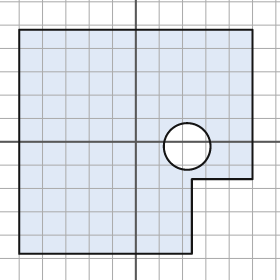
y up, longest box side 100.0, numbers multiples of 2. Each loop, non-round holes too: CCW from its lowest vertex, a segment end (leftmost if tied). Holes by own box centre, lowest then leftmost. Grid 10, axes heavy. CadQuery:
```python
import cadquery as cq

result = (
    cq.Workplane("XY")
    .moveTo(-50.0, -48.0)
    .lineTo(24.0, -48.0)
    .lineTo(24.0, -16.0)
    .lineTo(50.0, -16.0)
    .lineTo(50.0, 48.0)
    .lineTo(-50.0, 48.0)
    .close()
    .moveTo(22.0, -2.0)
    .circle(10.0)
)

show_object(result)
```